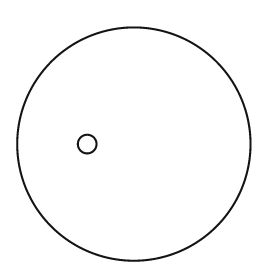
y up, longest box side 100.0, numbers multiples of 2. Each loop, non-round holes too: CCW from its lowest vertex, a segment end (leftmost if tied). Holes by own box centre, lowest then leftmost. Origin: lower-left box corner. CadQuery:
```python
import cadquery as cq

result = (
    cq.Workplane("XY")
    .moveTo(50.0, 50.0)
    .circle(50.0)
    .moveTo(30.0, 50.0)
    .circle(4.0)
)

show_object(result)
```